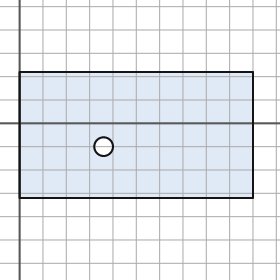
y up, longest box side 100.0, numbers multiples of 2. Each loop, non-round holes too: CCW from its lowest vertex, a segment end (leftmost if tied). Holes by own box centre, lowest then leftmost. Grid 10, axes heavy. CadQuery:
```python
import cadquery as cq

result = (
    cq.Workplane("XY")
    .moveTo(0.0, -32.0)
    .lineTo(100.0, -32.0)
    .lineTo(100.0, 22.0)
    .lineTo(0.0, 22.0)
    .close()
    .moveTo(36.0, -10.0)
    .circle(4.0)
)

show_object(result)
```